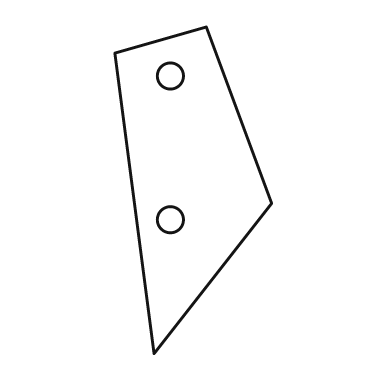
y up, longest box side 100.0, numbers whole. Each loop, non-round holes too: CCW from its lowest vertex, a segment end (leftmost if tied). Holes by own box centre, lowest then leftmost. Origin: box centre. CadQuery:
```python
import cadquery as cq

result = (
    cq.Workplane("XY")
    .moveTo(-12.0, -50.0)
    .lineTo(24.0, -4.0)
    .lineTo(4.0, 50.0)
    .lineTo(-24.0, 42.0)
    .close()
    .moveTo(-7.0, -9.0)
    .circle(4.0)
    .moveTo(-7.0, 35.0)
    .circle(4.0)
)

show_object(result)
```